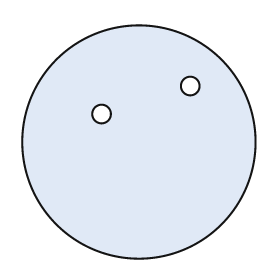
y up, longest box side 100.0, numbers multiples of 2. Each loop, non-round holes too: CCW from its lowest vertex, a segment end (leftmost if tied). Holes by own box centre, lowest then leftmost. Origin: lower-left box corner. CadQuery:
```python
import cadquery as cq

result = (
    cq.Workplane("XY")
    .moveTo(50.0, 50.0)
    .circle(50.0)
    .moveTo(34.0, 62.0)
    .circle(4.0)
    .moveTo(72.0, 74.0)
    .circle(4.0)
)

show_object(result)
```